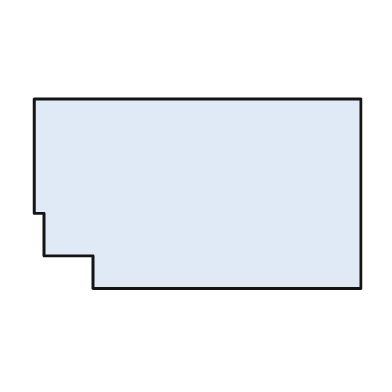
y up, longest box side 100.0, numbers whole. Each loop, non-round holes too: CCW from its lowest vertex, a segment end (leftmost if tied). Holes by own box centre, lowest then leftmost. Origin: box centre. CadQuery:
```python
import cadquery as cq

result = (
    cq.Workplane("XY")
    .moveTo(-32.0, -29.0)
    .lineTo(50.0, -29.0)
    .lineTo(50.0, 29.0)
    .lineTo(-50.0, 29.0)
    .lineTo(-50.0, -6.0)
    .lineTo(-47.0, -6.0)
    .lineTo(-47.0, -19.0)
    .lineTo(-32.0, -19.0)
    .close()
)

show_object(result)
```